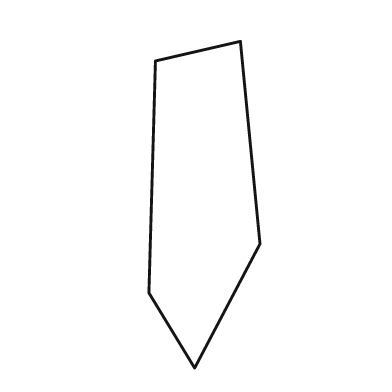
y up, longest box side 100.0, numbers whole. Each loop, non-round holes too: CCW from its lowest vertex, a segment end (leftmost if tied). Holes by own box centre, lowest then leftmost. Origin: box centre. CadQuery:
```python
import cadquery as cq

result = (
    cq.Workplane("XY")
    .moveTo(-3.0, -50.0)
    .lineTo(17.0, -12.0)
    .lineTo(11.0, 50.0)
    .lineTo(-15.0, 44.0)
    .lineTo(-17.0, -27.0)
    .close()
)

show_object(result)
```